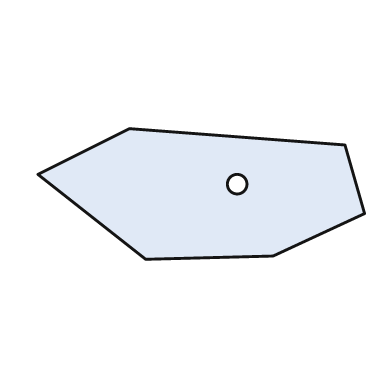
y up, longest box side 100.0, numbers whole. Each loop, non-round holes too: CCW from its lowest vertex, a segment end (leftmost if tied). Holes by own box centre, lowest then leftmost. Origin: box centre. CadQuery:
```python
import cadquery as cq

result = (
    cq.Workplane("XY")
    .moveTo(-17.0, -20.0)
    .lineTo(22.0, -19.0)
    .lineTo(50.0, -6.0)
    .lineTo(44.0, 15.0)
    .lineTo(-22.0, 20.0)
    .lineTo(-50.0, 6.0)
    .close()
    .moveTo(11.0, 3.0)
    .circle(3.0)
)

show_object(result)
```